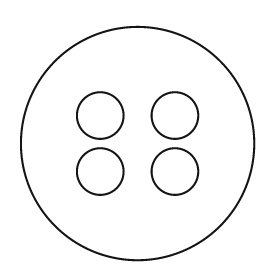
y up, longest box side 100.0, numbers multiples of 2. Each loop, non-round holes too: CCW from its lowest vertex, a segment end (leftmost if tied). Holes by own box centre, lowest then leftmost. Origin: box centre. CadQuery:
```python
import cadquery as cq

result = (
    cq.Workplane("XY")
    .moveTo(0.0, 0.0)
    .circle(50.0)
    .moveTo(-16.0, -12.0)
    .circle(10.0)
    .moveTo(16.0, -12.0)
    .circle(10.0)
    .moveTo(-16.0, 12.0)
    .circle(10.0)
    .moveTo(16.0, 12.0)
    .circle(10.0)
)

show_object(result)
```